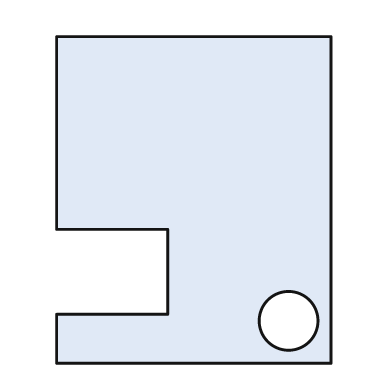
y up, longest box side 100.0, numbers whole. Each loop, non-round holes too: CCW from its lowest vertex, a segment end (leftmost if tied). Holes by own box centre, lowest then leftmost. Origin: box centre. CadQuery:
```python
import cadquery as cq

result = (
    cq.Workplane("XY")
    .moveTo(-42.0, -50.0)
    .lineTo(42.0, -50.0)
    .lineTo(42.0, 50.0)
    .lineTo(-42.0, 50.0)
    .lineTo(-42.0, -9.0)
    .lineTo(-8.0, -9.0)
    .lineTo(-8.0, -35.0)
    .lineTo(-42.0, -35.0)
    .close()
    .moveTo(29.0, -37.0)
    .circle(9.0)
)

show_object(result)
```